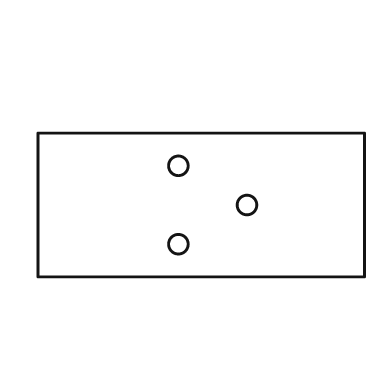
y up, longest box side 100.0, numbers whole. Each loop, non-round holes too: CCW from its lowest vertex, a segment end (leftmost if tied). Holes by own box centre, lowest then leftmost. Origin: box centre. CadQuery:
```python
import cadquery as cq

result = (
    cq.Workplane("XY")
    .moveTo(-50.0, -22.0)
    .lineTo(50.0, -22.0)
    .lineTo(50.0, 22.0)
    .lineTo(-50.0, 22.0)
    .close()
    .moveTo(-7.0, -12.0)
    .circle(3.0)
    .moveTo(14.0, 0.0)
    .circle(3.0)
    .moveTo(-7.0, 12.0)
    .circle(3.0)
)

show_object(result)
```